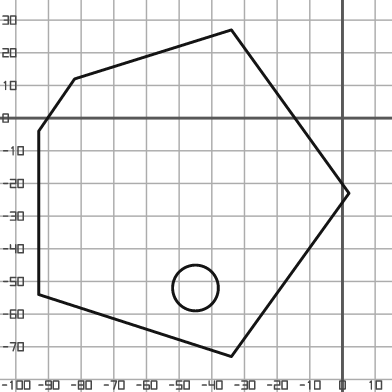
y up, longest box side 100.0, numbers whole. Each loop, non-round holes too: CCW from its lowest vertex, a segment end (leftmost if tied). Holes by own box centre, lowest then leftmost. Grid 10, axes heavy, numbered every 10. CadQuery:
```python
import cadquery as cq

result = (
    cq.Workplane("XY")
    .moveTo(-34.0, -73.0)
    .lineTo(2.0, -23.0)
    .lineTo(-34.0, 27.0)
    .lineTo(-82.0, 12.0)
    .lineTo(-93.0, -4.0)
    .lineTo(-93.0, -54.0)
    .close()
    .moveTo(-45.0, -52.0)
    .circle(7.0)
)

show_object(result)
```